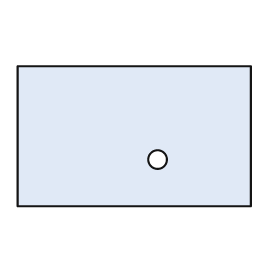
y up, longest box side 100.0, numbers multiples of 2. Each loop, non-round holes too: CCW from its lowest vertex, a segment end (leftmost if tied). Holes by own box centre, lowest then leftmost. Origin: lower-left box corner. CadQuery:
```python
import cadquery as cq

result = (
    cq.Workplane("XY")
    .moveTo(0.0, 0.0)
    .lineTo(100.0, 0.0)
    .lineTo(100.0, 60.0)
    .lineTo(0.0, 60.0)
    .close()
    .moveTo(60.0, 20.0)
    .circle(4.0)
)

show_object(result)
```